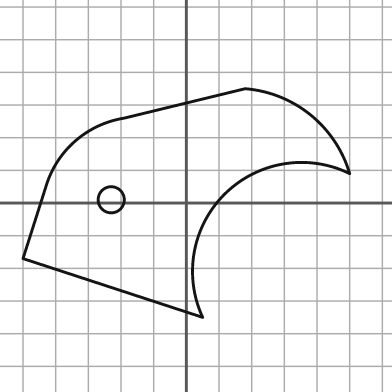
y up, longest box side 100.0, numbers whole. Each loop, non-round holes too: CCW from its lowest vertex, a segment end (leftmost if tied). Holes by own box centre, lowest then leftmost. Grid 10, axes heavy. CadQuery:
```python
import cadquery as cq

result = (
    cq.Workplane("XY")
    .moveTo(5.0, -35.0)
    .threePointArc((12.0, 3.0), (50.0, 9.0))
    .threePointArc((38.0, 27.0), (18.0, 35.0))
    .lineTo(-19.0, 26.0)
    .threePointArc((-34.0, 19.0), (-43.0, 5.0))
    .lineTo(-50.0, -17.0)
    .close()
    .moveTo(-23.0, 1.0)
    .circle(4.0)
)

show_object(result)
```